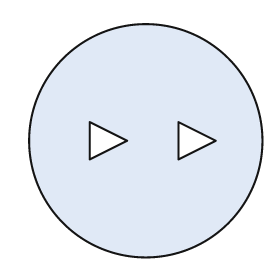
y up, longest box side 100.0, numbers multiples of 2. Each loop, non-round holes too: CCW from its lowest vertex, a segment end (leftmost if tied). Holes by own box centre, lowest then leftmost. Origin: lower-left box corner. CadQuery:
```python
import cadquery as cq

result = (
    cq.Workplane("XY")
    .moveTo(50.0, 50.0)
    .circle(50.0)
    .moveTo(26.0, 42.0)
    .lineTo(42.0, 50.0)
    .lineTo(26.0, 58.0)
    .close()
    .moveTo(64.0, 42.0)
    .lineTo(80.0, 50.0)
    .lineTo(64.0, 58.0)
    .close()
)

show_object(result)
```